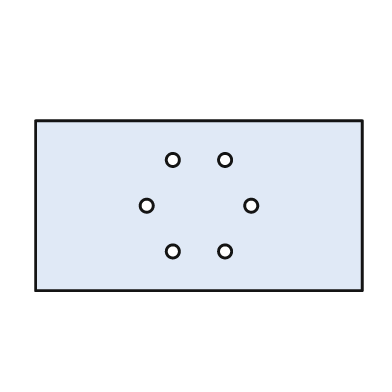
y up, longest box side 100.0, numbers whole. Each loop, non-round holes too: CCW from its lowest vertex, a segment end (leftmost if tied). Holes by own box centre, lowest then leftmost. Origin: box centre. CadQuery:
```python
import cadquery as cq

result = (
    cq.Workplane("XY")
    .moveTo(-50.0, -26.0)
    .lineTo(50.0, -26.0)
    .lineTo(50.0, 26.0)
    .lineTo(-50.0, 26.0)
    .close()
    .moveTo(-8.0, -14.0)
    .circle(2.0)
    .moveTo(8.0, -14.0)
    .circle(2.0)
    .moveTo(-16.0, 0.0)
    .circle(2.0)
    .moveTo(16.0, 0.0)
    .circle(2.0)
    .moveTo(-8.0, 14.0)
    .circle(2.0)
    .moveTo(8.0, 14.0)
    .circle(2.0)
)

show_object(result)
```